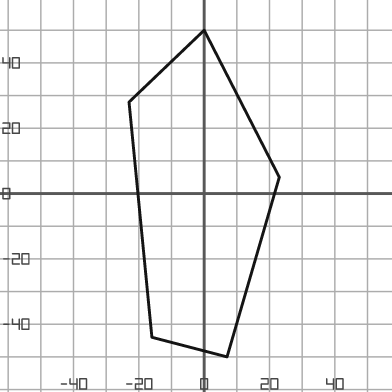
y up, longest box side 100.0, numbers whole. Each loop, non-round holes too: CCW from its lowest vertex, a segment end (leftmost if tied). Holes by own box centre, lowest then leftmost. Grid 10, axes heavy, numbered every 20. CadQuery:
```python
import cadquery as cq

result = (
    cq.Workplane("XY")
    .moveTo(7.0, -50.0)
    .lineTo(23.0, 5.0)
    .lineTo(0.0, 50.0)
    .lineTo(-23.0, 28.0)
    .lineTo(-16.0, -44.0)
    .close()
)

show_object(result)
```